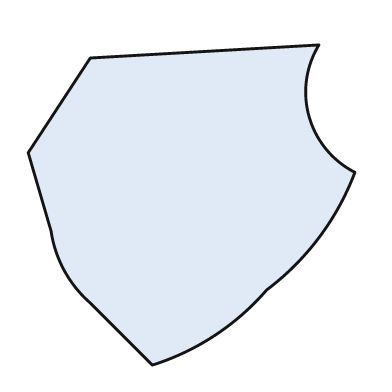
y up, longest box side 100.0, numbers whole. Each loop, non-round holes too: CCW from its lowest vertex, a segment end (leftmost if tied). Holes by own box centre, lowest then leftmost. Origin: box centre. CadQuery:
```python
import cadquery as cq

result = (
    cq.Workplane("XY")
    .moveTo(-12.0, -49.0)
    .threePointArc((7.0, -40.0), (23.0, -26.0))
    .threePointArc((39.0, -10.0), (50.0, 10.0))
    .threePointArc((36.0, 27.0), (39.0, 49.0))
    .lineTo(-31.0, 45.0)
    .lineTo(-50.0, 16.0)
    .lineTo(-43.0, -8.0)
    .threePointArc((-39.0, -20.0), (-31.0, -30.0))
    .close()
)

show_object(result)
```